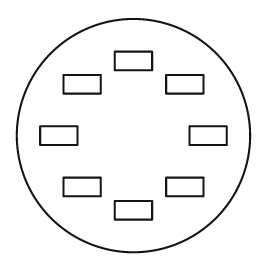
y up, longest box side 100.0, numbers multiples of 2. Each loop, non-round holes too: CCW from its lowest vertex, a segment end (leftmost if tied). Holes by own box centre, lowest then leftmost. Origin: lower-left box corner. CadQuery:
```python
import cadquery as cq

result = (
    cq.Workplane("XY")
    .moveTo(50.0, 50.0)
    .circle(50.0)
    .moveTo(42.0, 14.0)
    .lineTo(58.0, 14.0)
    .lineTo(58.0, 22.0)
    .lineTo(42.0, 22.0)
    .close()
    .moveTo(20.0, 24.0)
    .lineTo(36.0, 24.0)
    .lineTo(36.0, 32.0)
    .lineTo(20.0, 32.0)
    .close()
    .moveTo(64.0, 24.0)
    .lineTo(80.0, 24.0)
    .lineTo(80.0, 32.0)
    .lineTo(64.0, 32.0)
    .close()
    .moveTo(10.0, 46.0)
    .lineTo(26.0, 46.0)
    .lineTo(26.0, 54.0)
    .lineTo(10.0, 54.0)
    .close()
    .moveTo(74.0, 46.0)
    .lineTo(90.0, 46.0)
    .lineTo(90.0, 54.0)
    .lineTo(74.0, 54.0)
    .close()
    .moveTo(20.0, 68.0)
    .lineTo(36.0, 68.0)
    .lineTo(36.0, 76.0)
    .lineTo(20.0, 76.0)
    .close()
    .moveTo(64.0, 68.0)
    .lineTo(80.0, 68.0)
    .lineTo(80.0, 76.0)
    .lineTo(64.0, 76.0)
    .close()
    .moveTo(42.0, 78.0)
    .lineTo(58.0, 78.0)
    .lineTo(58.0, 86.0)
    .lineTo(42.0, 86.0)
    .close()
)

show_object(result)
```